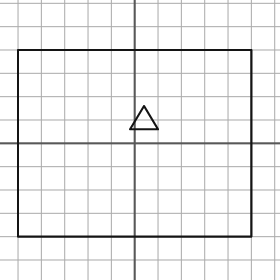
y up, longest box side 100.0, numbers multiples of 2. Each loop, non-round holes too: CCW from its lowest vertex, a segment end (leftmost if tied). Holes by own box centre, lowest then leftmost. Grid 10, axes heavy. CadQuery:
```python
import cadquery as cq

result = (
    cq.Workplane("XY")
    .moveTo(-50.0, -40.0)
    .lineTo(50.0, -40.0)
    .lineTo(50.0, 40.0)
    .lineTo(-50.0, 40.0)
    .close()
    .moveTo(-2.0, 6.0)
    .lineTo(10.0, 6.0)
    .lineTo(4.0, 16.0)
    .close()
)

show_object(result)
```